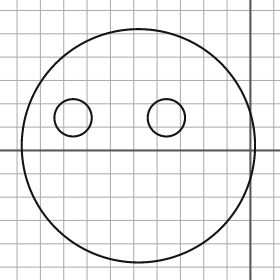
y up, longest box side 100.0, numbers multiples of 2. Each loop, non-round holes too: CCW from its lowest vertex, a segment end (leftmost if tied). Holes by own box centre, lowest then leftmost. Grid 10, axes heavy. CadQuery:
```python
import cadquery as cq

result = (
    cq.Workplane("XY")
    .moveTo(-48.0, 2.0)
    .circle(50.0)
    .moveTo(-76.0, 14.0)
    .circle(8.0)
    .moveTo(-36.0, 14.0)
    .circle(8.0)
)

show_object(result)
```